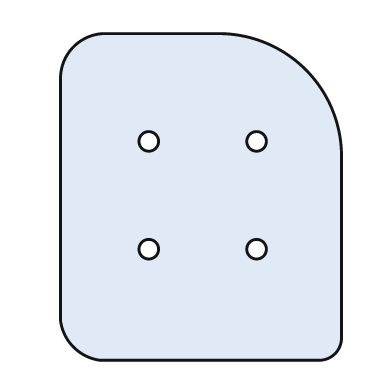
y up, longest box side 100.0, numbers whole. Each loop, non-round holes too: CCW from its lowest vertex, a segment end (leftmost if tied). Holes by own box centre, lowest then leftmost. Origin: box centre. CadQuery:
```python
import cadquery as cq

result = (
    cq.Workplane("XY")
    .moveTo(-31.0, -50.0)
    .lineTo(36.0, -50.0)
    .threePointArc((41.0, -48.0), (43.0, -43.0))
    .lineTo(43.0, 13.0)
    .threePointArc((32.0, 39.0), (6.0, 50.0))
    .lineTo(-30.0, 50.0)
    .threePointArc((-39.0, 46.0), (-43.0, 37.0))
    .lineTo(-43.0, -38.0)
    .threePointArc((-39.0, -46.0), (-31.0, -50.0))
    .close()
    .moveTo(-16.0, -16.0)
    .circle(3.0)
    .moveTo(17.0, -16.0)
    .circle(3.0)
    .moveTo(-16.0, 17.0)
    .circle(3.0)
    .moveTo(17.0, 17.0)
    .circle(3.0)
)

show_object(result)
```